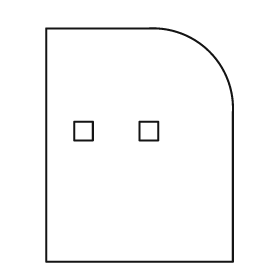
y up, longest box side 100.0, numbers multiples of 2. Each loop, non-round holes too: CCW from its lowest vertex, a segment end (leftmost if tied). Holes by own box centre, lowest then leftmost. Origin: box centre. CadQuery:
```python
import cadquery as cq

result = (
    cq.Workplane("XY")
    .moveTo(-40.0, -50.0)
    .lineTo(40.0, -50.0)
    .lineTo(40.0, 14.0)
    .threePointArc((30.0, 40.0), (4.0, 50.0))
    .lineTo(-40.0, 50.0)
    .close()
    .moveTo(-28.0, 2.0)
    .lineTo(-20.0, 2.0)
    .lineTo(-20.0, 10.0)
    .lineTo(-28.0, 10.0)
    .close()
    .moveTo(0.0, 2.0)
    .lineTo(8.0, 2.0)
    .lineTo(8.0, 10.0)
    .lineTo(0.0, 10.0)
    .close()
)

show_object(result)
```